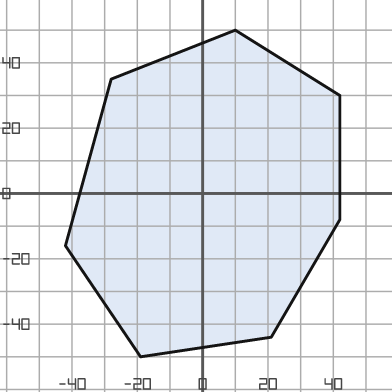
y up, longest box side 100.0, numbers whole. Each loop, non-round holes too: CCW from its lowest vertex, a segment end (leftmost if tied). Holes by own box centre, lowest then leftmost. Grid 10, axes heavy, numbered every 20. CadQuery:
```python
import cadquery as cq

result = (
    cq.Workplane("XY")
    .moveTo(-19.0, -50.0)
    .lineTo(21.0, -44.0)
    .lineTo(42.0, -8.0)
    .lineTo(42.0, 30.0)
    .lineTo(10.0, 50.0)
    .lineTo(-28.0, 35.0)
    .lineTo(-42.0, -16.0)
    .close()
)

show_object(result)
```